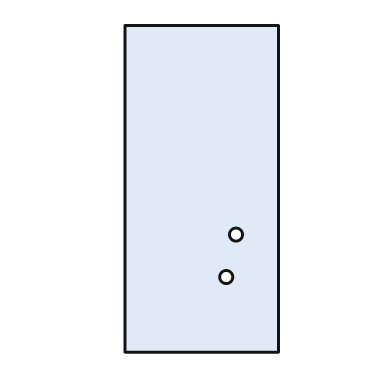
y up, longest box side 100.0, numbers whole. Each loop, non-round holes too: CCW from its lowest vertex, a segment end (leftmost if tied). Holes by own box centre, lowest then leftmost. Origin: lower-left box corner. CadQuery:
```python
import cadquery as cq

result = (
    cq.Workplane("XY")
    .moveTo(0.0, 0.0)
    .lineTo(47.0, 0.0)
    .lineTo(47.0, 100.0)
    .lineTo(0.0, 100.0)
    .close()
    .moveTo(31.0, 23.0)
    .circle(2.0)
    .moveTo(34.0, 36.0)
    .circle(2.0)
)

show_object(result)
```